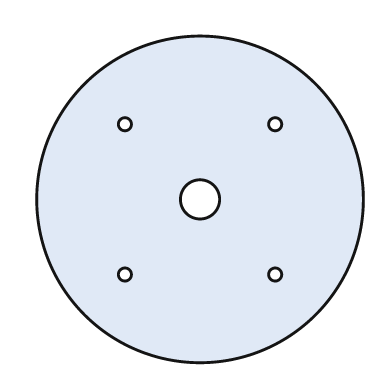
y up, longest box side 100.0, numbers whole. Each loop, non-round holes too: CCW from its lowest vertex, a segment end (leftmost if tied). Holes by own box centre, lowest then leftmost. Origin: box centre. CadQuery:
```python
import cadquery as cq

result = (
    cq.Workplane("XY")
    .moveTo(0.0, 0.0)
    .circle(50.0)
    .moveTo(-23.0, -23.0)
    .circle(2.0)
    .moveTo(23.0, -23.0)
    .circle(2.0)
    .moveTo(0.0, 0.0)
    .circle(6.0)
    .moveTo(-23.0, 23.0)
    .circle(2.0)
    .moveTo(23.0, 23.0)
    .circle(2.0)
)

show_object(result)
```